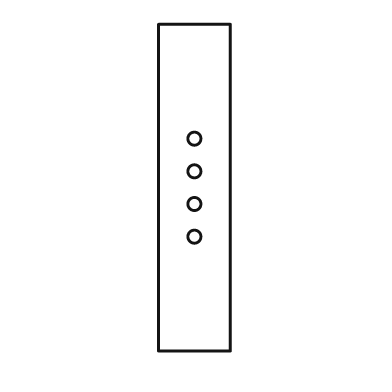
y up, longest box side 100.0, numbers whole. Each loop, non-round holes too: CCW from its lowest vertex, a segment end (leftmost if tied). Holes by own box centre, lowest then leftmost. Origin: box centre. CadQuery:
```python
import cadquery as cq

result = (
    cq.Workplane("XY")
    .moveTo(-11.0, -50.0)
    .lineTo(11.0, -50.0)
    .lineTo(11.0, 50.0)
    .lineTo(-11.0, 50.0)
    .close()
    .moveTo(0.0, -15.0)
    .circle(2.0)
    .moveTo(0.0, -5.0)
    .circle(2.0)
    .moveTo(0.0, 5.0)
    .circle(2.0)
    .moveTo(0.0, 15.0)
    .circle(2.0)
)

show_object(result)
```